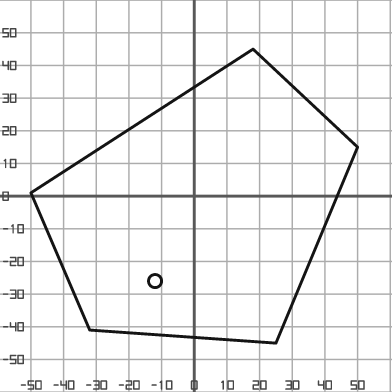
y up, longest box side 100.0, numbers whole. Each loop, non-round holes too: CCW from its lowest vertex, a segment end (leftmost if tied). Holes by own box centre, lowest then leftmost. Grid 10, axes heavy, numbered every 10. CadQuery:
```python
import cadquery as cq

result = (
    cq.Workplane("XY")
    .moveTo(25.0, -45.0)
    .lineTo(50.0, 15.0)
    .lineTo(18.0, 45.0)
    .lineTo(-50.0, 1.0)
    .lineTo(-32.0, -41.0)
    .close()
    .moveTo(-12.0, -26.0)
    .circle(2.0)
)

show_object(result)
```